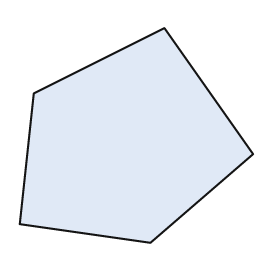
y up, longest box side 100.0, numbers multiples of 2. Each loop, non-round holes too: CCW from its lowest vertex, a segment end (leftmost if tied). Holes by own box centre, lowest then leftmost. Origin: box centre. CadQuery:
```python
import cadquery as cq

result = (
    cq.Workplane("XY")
    .moveTo(6.0, -46.0)
    .lineTo(50.0, -8.0)
    .lineTo(12.0, 46.0)
    .lineTo(-44.0, 18.0)
    .lineTo(-50.0, -38.0)
    .close()
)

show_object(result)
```